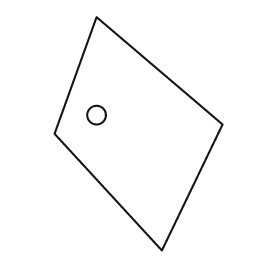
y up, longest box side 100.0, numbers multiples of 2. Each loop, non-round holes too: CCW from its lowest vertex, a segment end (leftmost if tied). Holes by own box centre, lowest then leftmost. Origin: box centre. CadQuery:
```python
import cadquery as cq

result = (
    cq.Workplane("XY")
    .moveTo(10.0, -50.0)
    .lineTo(36.0, 4.0)
    .lineTo(-18.0, 50.0)
    .lineTo(-36.0, 0.0)
    .close()
    .moveTo(-18.0, 8.0)
    .circle(4.0)
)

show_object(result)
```